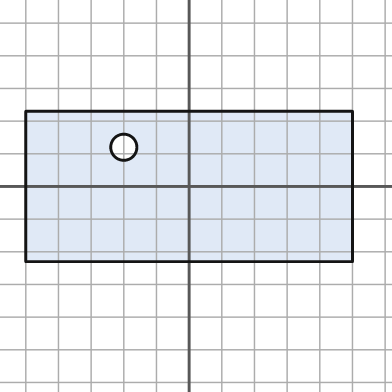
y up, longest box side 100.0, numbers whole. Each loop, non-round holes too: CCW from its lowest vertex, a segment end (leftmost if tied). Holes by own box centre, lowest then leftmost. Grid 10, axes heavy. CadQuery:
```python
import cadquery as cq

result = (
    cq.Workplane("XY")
    .moveTo(-50.0, -23.0)
    .lineTo(50.0, -23.0)
    .lineTo(50.0, 23.0)
    .lineTo(-50.0, 23.0)
    .close()
    .moveTo(-20.0, 12.0)
    .circle(4.0)
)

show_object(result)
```